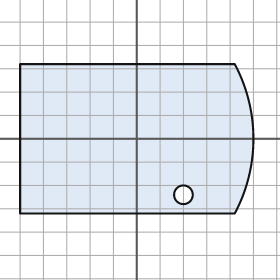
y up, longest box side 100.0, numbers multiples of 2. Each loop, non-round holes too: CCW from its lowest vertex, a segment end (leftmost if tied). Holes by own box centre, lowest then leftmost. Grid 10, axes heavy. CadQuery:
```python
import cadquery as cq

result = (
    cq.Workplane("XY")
    .moveTo(-50.0, -32.0)
    .lineTo(42.0, -32.0)
    .threePointArc((50.0, 0.0), (42.0, 32.0))
    .lineTo(-50.0, 32.0)
    .close()
    .moveTo(20.0, -24.0)
    .circle(4.0)
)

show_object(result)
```